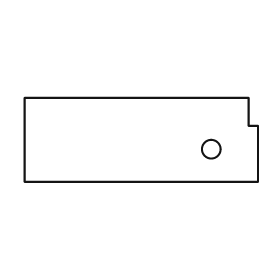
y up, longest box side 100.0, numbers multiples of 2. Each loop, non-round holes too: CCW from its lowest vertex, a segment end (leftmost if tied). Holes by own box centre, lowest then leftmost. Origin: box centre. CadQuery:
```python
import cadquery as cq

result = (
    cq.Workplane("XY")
    .moveTo(-50.0, -18.0)
    .lineTo(50.0, -18.0)
    .lineTo(50.0, 6.0)
    .lineTo(46.0, 6.0)
    .lineTo(46.0, 18.0)
    .lineTo(-50.0, 18.0)
    .close()
    .moveTo(30.0, -4.0)
    .circle(4.0)
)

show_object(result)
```